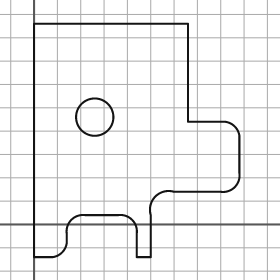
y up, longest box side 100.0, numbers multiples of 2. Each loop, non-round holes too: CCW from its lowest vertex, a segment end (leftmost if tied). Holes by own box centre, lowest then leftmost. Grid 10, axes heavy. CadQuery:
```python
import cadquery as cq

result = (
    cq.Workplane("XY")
    .moveTo(0.0, -14.0)
    .lineTo(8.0, -14.0)
    .threePointArc((12.0, -12.0), (14.0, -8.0))
    .lineTo(14.0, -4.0)
    .threePointArc((16.0, 2.0), (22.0, 4.0))
    .lineTo(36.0, 4.0)
    .threePointArc((42.0, 2.0), (44.0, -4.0))
    .lineTo(44.0, -14.0)
    .lineTo(50.0, -14.0)
    .lineTo(50.0, 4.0)
    .threePointArc((52.0, 12.0), (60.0, 14.0))
    .lineTo(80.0, 14.0)
    .threePointArc((86.0, 16.0), (88.0, 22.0))
    .lineTo(88.0, 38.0)
    .threePointArc((86.0, 42.0), (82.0, 44.0))
    .lineTo(66.0, 44.0)
    .lineTo(66.0, 86.0)
    .lineTo(0.0, 86.0)
    .close()
    .moveTo(26.0, 46.0)
    .circle(8.0)
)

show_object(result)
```